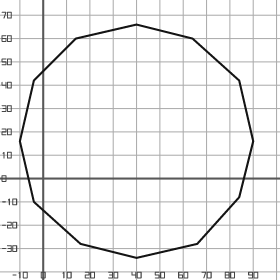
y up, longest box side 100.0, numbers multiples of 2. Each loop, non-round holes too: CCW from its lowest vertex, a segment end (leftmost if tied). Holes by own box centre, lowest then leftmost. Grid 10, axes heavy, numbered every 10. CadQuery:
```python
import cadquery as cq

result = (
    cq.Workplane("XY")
    .moveTo(40.0, -34.0)
    .lineTo(66.0, -28.0)
    .lineTo(84.0, -8.0)
    .lineTo(90.0, 16.0)
    .lineTo(84.0, 42.0)
    .lineTo(64.0, 60.0)
    .lineTo(40.0, 66.0)
    .lineTo(14.0, 60.0)
    .lineTo(-4.0, 42.0)
    .lineTo(-10.0, 16.0)
    .lineTo(-4.0, -10.0)
    .lineTo(16.0, -28.0)
    .close()
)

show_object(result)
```